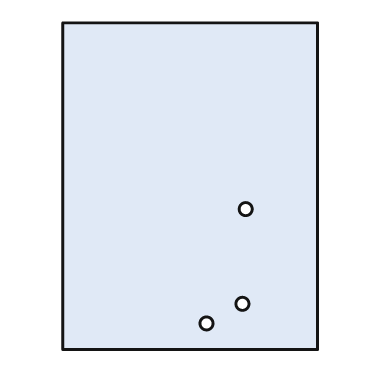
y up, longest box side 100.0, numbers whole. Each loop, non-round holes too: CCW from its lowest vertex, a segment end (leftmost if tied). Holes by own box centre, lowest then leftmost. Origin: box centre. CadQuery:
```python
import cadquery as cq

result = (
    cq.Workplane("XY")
    .moveTo(-39.0, -50.0)
    .lineTo(39.0, -50.0)
    .lineTo(39.0, 50.0)
    .lineTo(-39.0, 50.0)
    .close()
    .moveTo(5.0, -42.0)
    .circle(2.0)
    .moveTo(16.0, -36.0)
    .circle(2.0)
    .moveTo(17.0, -7.0)
    .circle(2.0)
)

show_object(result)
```